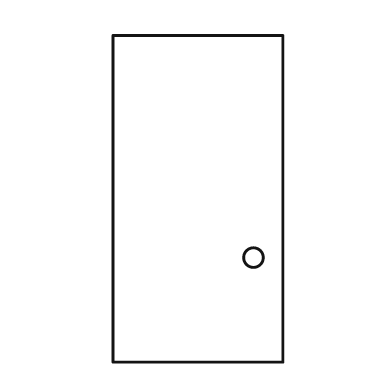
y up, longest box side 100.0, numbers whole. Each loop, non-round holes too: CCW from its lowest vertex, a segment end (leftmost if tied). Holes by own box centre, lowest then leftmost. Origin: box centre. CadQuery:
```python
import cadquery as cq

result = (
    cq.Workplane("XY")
    .moveTo(-26.0, -50.0)
    .lineTo(26.0, -50.0)
    .lineTo(26.0, 50.0)
    .lineTo(-26.0, 50.0)
    .close()
    .moveTo(17.0, -18.0)
    .circle(3.0)
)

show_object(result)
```